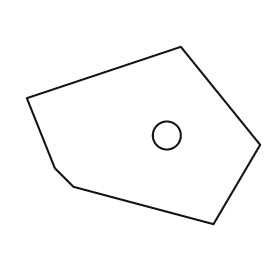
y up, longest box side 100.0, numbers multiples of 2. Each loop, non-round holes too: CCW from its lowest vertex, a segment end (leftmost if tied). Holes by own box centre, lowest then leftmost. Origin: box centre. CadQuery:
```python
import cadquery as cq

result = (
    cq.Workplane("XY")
    .moveTo(30.0, -38.0)
    .lineTo(50.0, -4.0)
    .lineTo(16.0, 38.0)
    .lineTo(-50.0, 16.0)
    .lineTo(-38.0, -14.0)
    .lineTo(-30.0, -22.0)
    .close()
    .moveTo(10.0, 0.0)
    .circle(6.0)
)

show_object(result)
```